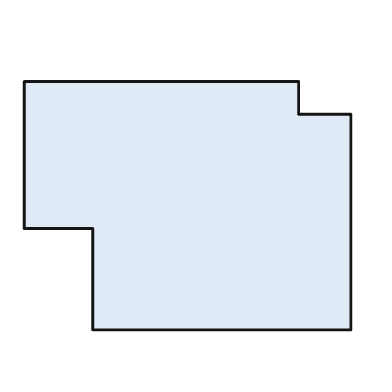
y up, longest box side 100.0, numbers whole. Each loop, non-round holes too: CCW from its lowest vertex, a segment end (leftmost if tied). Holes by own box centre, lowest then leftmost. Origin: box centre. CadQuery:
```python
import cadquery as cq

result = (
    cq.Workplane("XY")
    .moveTo(-29.0, -38.0)
    .lineTo(50.0, -38.0)
    .lineTo(50.0, 28.0)
    .lineTo(34.0, 28.0)
    .lineTo(34.0, 38.0)
    .lineTo(-50.0, 38.0)
    .lineTo(-50.0, -7.0)
    .lineTo(-29.0, -7.0)
    .close()
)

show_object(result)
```